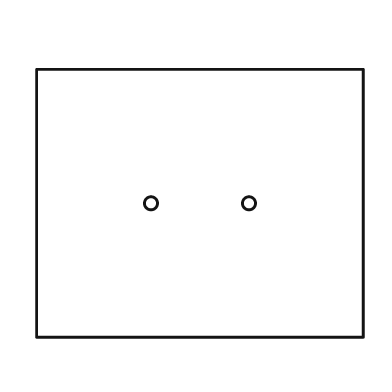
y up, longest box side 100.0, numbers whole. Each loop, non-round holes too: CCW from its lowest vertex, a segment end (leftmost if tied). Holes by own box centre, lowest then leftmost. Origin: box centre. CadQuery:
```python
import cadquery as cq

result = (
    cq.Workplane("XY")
    .moveTo(-50.0, -41.0)
    .lineTo(50.0, -41.0)
    .lineTo(50.0, 41.0)
    .lineTo(-50.0, 41.0)
    .close()
    .moveTo(-15.0, 0.0)
    .circle(2.0)
    .moveTo(15.0, 0.0)
    .circle(2.0)
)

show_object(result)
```